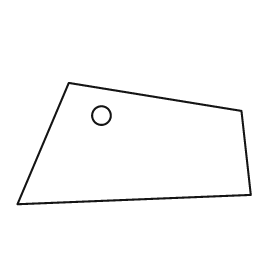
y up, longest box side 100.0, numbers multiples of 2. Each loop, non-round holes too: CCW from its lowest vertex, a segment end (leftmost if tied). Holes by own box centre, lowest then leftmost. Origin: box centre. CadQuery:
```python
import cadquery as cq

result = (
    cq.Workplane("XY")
    .moveTo(-50.0, -26.0)
    .lineTo(50.0, -22.0)
    .lineTo(46.0, 14.0)
    .lineTo(-28.0, 26.0)
    .close()
    .moveTo(-14.0, 12.0)
    .circle(4.0)
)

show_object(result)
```